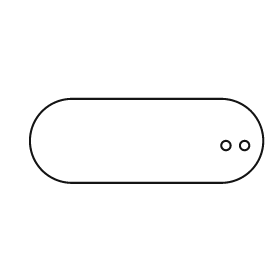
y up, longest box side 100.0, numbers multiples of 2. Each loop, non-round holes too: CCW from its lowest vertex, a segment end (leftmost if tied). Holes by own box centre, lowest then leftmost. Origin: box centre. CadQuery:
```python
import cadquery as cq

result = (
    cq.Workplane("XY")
    .moveTo(-32.0, -18.0)
    .lineTo(32.0, -18.0)
    .threePointArc((50.0, 0.0), (32.0, 18.0))
    .lineTo(-32.0, 18.0)
    .threePointArc((-50.0, 0.0), (-32.0, -18.0))
    .close()
    .moveTo(34.0, -2.0)
    .circle(2.0)
    .moveTo(42.0, -2.0)
    .circle(2.0)
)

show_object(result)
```